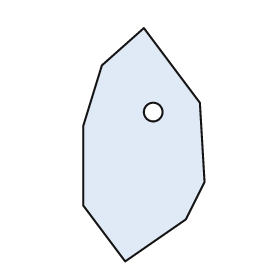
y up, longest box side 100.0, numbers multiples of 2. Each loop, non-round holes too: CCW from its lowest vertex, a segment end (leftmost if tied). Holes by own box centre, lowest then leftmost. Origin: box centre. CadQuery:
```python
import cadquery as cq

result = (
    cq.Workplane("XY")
    .moveTo(-8.0, -50.0)
    .lineTo(18.0, -32.0)
    .lineTo(26.0, -16.0)
    .lineTo(24.0, 18.0)
    .lineTo(0.0, 50.0)
    .lineTo(-18.0, 34.0)
    .lineTo(-26.0, 8.0)
    .lineTo(-26.0, -26.0)
    .close()
    .moveTo(4.0, 14.0)
    .circle(4.0)
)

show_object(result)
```